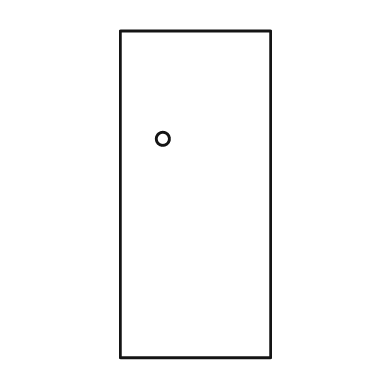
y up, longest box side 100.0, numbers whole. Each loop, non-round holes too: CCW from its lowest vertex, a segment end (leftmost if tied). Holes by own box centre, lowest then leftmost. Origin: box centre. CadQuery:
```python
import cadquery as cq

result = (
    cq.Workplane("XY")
    .moveTo(-23.0, -50.0)
    .lineTo(23.0, -50.0)
    .lineTo(23.0, 50.0)
    .lineTo(-23.0, 50.0)
    .close()
    .moveTo(-10.0, 17.0)
    .circle(2.0)
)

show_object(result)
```